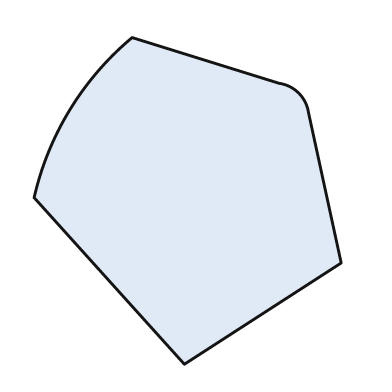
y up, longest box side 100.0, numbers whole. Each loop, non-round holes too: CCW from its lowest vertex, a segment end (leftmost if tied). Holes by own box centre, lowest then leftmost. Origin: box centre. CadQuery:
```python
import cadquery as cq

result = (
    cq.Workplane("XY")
    .moveTo(-1.0, -50.0)
    .lineTo(47.0, -19.0)
    .lineTo(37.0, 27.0)
    .threePointArc((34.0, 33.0), (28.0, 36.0))
    .lineTo(-17.0, 50.0)
    .threePointArc((-36.0, 28.0), (-47.0, 1.0))
    .close()
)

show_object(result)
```